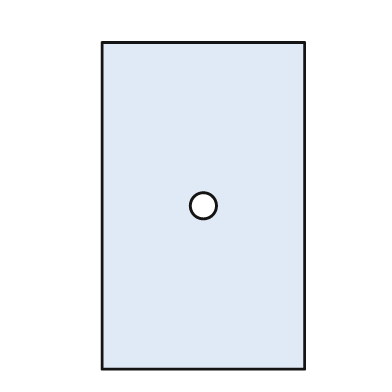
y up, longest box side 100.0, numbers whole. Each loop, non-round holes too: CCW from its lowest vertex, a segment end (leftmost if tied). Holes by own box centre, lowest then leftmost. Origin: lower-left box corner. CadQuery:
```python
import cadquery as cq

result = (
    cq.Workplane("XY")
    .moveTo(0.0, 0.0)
    .lineTo(62.0, 0.0)
    .lineTo(62.0, 100.0)
    .lineTo(0.0, 100.0)
    .close()
    .moveTo(31.0, 50.0)
    .circle(4.0)
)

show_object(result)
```